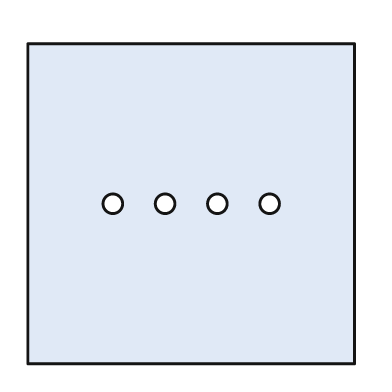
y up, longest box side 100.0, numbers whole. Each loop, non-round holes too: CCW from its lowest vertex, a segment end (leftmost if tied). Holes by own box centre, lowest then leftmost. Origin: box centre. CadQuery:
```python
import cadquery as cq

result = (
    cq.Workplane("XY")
    .moveTo(-50.0, -49.0)
    .lineTo(50.0, -49.0)
    .lineTo(50.0, 49.0)
    .lineTo(-50.0, 49.0)
    .close()
    .moveTo(-24.0, 0.0)
    .circle(3.0)
    .moveTo(-8.0, 0.0)
    .circle(3.0)
    .moveTo(8.0, 0.0)
    .circle(3.0)
    .moveTo(24.0, 0.0)
    .circle(3.0)
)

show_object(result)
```